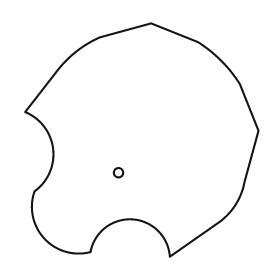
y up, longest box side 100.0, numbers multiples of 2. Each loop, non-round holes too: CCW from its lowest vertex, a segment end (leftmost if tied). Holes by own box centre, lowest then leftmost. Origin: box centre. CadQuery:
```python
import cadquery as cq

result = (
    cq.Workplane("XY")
    .moveTo(12.0, -50.0)
    .lineTo(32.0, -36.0)
    .threePointArc((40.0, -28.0), (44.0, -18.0))
    .lineTo(50.0, 4.0)
    .lineTo(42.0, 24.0)
    .threePointArc((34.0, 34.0), (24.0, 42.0))
    .lineTo(4.0, 50.0)
    .lineTo(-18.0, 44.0)
    .threePointArc((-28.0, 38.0), (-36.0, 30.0))
    .lineTo(-50.0, 12.0)
    .threePointArc((-38.0, -4.0), (-46.0, -22.0))
    .threePointArc((-42.0, -42.0), (-22.0, -48.0))
    .threePointArc((-4.0, -34.0), (12.0, -50.0))
    .close()
    .moveTo(-10.0, -14.0)
    .circle(2.0)
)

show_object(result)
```